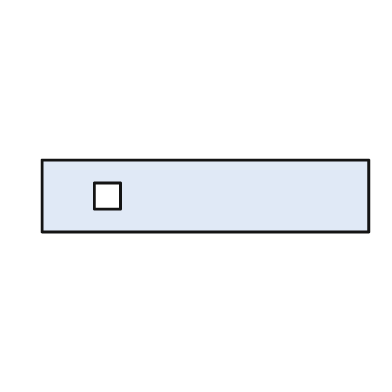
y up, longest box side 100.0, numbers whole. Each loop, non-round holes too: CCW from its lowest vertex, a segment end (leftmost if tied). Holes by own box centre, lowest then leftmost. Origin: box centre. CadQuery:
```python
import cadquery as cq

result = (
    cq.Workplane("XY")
    .moveTo(-50.0, -11.0)
    .lineTo(50.0, -11.0)
    .lineTo(50.0, 11.0)
    .lineTo(-50.0, 11.0)
    .close()
    .moveTo(-34.0, -4.0)
    .lineTo(-26.0, -4.0)
    .lineTo(-26.0, 4.0)
    .lineTo(-34.0, 4.0)
    .close()
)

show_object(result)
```